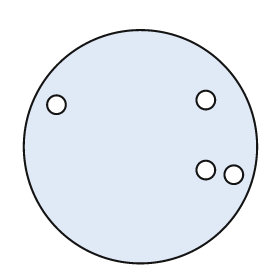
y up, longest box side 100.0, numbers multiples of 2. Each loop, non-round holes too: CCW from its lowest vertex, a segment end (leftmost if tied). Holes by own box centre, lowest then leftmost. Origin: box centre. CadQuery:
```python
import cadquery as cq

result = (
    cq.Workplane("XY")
    .moveTo(0.0, 0.0)
    .circle(50.0)
    .moveTo(40.0, -12.0)
    .circle(4.0)
    .moveTo(28.0, -10.0)
    .circle(4.0)
    .moveTo(-36.0, 18.0)
    .circle(4.0)
    .moveTo(28.0, 20.0)
    .circle(4.0)
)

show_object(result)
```